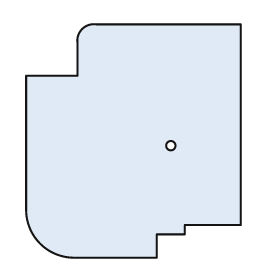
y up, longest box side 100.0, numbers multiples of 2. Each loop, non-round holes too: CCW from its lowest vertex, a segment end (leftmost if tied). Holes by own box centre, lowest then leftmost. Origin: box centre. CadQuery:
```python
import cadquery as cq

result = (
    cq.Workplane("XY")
    .moveTo(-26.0, -50.0)
    .lineTo(10.0, -50.0)
    .lineTo(10.0, -40.0)
    .lineTo(22.0, -40.0)
    .lineTo(22.0, -36.0)
    .lineTo(46.0, -36.0)
    .lineTo(46.0, 50.0)
    .lineTo(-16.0, 50.0)
    .threePointArc((-22.0, 48.0), (-24.0, 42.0))
    .lineTo(-24.0, 28.0)
    .lineTo(-46.0, 28.0)
    .lineTo(-46.0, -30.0)
    .threePointArc((-40.0, -44.0), (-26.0, -50.0))
    .close()
    .moveTo(16.0, -2.0)
    .circle(2.0)
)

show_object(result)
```